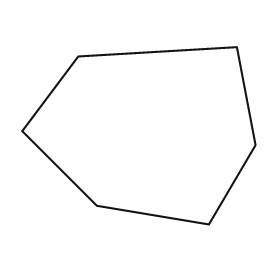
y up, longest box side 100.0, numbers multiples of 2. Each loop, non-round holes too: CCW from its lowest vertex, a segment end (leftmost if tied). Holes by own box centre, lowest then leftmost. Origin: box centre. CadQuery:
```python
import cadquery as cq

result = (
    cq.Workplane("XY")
    .moveTo(30.0, -38.0)
    .lineTo(50.0, -4.0)
    .lineTo(42.0, 38.0)
    .lineTo(-26.0, 34.0)
    .lineTo(-50.0, 2.0)
    .lineTo(-18.0, -30.0)
    .close()
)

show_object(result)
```